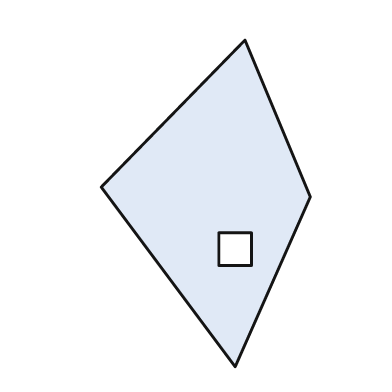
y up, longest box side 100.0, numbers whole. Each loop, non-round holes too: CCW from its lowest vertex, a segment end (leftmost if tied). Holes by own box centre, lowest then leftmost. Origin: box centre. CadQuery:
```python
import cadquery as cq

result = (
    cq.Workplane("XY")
    .moveTo(9.0, -50.0)
    .lineTo(32.0, 2.0)
    .lineTo(12.0, 50.0)
    .lineTo(-32.0, 5.0)
    .close()
    .moveTo(4.0, -19.0)
    .lineTo(14.0, -19.0)
    .lineTo(14.0, -9.0)
    .lineTo(4.0, -9.0)
    .close()
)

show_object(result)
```